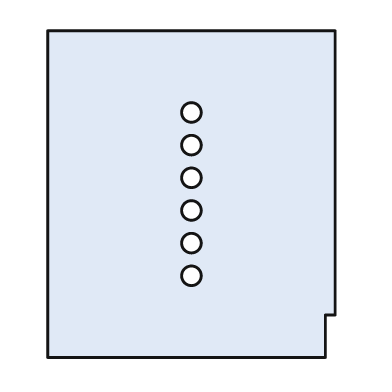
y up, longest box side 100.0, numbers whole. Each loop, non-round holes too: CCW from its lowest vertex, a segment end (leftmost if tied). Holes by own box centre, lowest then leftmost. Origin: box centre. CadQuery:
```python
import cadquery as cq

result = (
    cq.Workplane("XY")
    .moveTo(-44.0, -50.0)
    .lineTo(41.0, -50.0)
    .lineTo(41.0, -37.0)
    .lineTo(44.0, -37.0)
    .lineTo(44.0, 50.0)
    .lineTo(-44.0, 50.0)
    .close()
    .moveTo(0.0, -25.0)
    .circle(3.0)
    .moveTo(0.0, -15.0)
    .circle(3.0)
    .moveTo(0.0, -5.0)
    .circle(3.0)
    .moveTo(0.0, 5.0)
    .circle(3.0)
    .moveTo(0.0, 15.0)
    .circle(3.0)
    .moveTo(0.0, 25.0)
    .circle(3.0)
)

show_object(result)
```